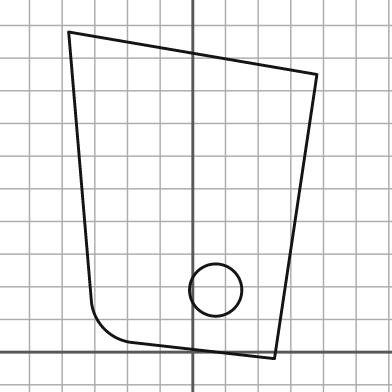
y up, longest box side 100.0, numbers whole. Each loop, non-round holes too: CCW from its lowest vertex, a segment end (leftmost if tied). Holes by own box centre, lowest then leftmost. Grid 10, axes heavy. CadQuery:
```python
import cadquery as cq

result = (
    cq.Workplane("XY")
    .moveTo(25.0, -2.0)
    .lineTo(38.0, 85.0)
    .lineTo(-38.0, 98.0)
    .lineTo(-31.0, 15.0)
    .threePointArc((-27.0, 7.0), (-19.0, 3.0))
    .close()
    .moveTo(7.0, 19.0)
    .circle(8.0)
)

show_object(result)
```